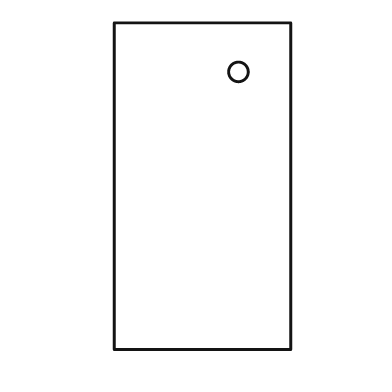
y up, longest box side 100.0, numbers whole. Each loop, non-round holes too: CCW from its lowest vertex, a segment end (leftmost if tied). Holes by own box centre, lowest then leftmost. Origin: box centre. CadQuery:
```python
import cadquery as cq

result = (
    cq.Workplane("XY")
    .moveTo(-27.0, -50.0)
    .lineTo(27.0, -50.0)
    .lineTo(27.0, 50.0)
    .lineTo(-27.0, 50.0)
    .close()
    .moveTo(11.0, 35.0)
    .circle(3.0)
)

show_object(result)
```